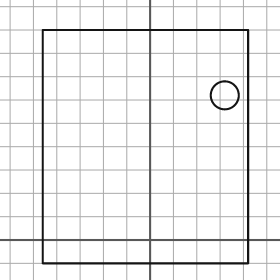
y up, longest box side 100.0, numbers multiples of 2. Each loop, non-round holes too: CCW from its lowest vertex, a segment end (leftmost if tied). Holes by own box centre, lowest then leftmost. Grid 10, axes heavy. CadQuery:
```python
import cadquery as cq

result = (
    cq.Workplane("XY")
    .moveTo(-46.0, -10.0)
    .lineTo(42.0, -10.0)
    .lineTo(42.0, 90.0)
    .lineTo(-46.0, 90.0)
    .close()
    .moveTo(32.0, 62.0)
    .circle(6.0)
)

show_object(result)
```